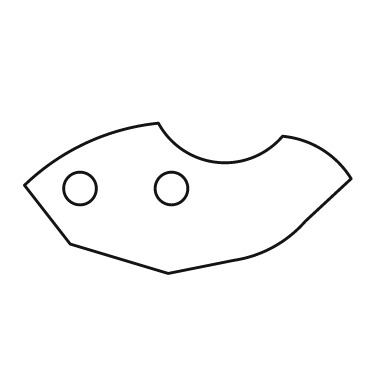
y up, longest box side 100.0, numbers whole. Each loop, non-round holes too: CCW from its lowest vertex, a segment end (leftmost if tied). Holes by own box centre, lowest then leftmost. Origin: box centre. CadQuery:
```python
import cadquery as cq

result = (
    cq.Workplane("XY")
    .moveTo(-6.0, -23.0)
    .lineTo(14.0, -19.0)
    .threePointArc((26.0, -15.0), (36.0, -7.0))
    .lineTo(50.0, 6.0)
    .threePointArc((41.0, 15.0), (29.0, 19.0))
    .threePointArc((9.0, 11.0), (-9.0, 23.0))
    .threePointArc((-31.0, 17.0), (-50.0, 4.0))
    .lineTo(-36.0, -14.0)
    .close()
    .moveTo(-33.0, 3.0)
    .circle(5.0)
    .moveTo(-5.0, 3.0)
    .circle(5.0)
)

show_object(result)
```